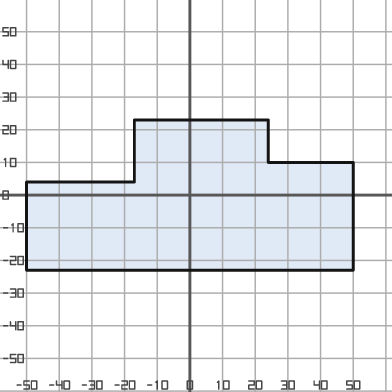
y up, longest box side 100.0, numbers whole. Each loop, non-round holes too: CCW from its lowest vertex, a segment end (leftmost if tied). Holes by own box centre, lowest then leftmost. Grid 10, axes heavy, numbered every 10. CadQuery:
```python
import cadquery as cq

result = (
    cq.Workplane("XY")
    .moveTo(-50.0, -23.0)
    .lineTo(50.0, -23.0)
    .lineTo(50.0, 10.0)
    .lineTo(24.0, 10.0)
    .lineTo(24.0, 23.0)
    .lineTo(-17.0, 23.0)
    .lineTo(-17.0, 4.0)
    .lineTo(-50.0, 4.0)
    .close()
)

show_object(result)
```